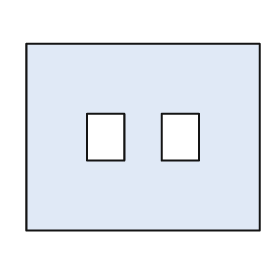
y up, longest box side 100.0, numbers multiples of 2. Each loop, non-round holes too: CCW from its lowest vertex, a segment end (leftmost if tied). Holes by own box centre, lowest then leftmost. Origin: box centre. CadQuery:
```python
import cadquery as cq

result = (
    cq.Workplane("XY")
    .moveTo(-50.0, -40.0)
    .lineTo(50.0, -40.0)
    .lineTo(50.0, 40.0)
    .lineTo(-50.0, 40.0)
    .close()
    .moveTo(-24.0, -10.0)
    .lineTo(-8.0, -10.0)
    .lineTo(-8.0, 10.0)
    .lineTo(-24.0, 10.0)
    .close()
    .moveTo(8.0, -10.0)
    .lineTo(24.0, -10.0)
    .lineTo(24.0, 10.0)
    .lineTo(8.0, 10.0)
    .close()
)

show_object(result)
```